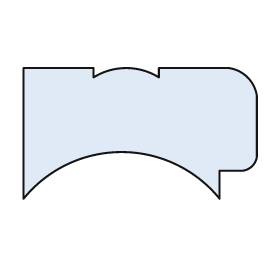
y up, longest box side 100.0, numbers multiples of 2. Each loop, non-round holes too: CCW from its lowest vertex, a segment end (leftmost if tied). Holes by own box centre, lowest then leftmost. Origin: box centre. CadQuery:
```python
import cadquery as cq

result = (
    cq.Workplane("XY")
    .moveTo(-50.0, -28.0)
    .threePointArc((-8.0, -8.0), (34.0, -28.0))
    .lineTo(34.0, -16.0)
    .lineTo(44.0, -16.0)
    .threePointArc((48.0, -14.0), (50.0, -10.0))
    .lineTo(50.0, 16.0)
    .threePointArc((46.0, 24.0), (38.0, 28.0))
    .lineTo(8.0, 28.0)
    .lineTo(8.0, 24.0)
    .threePointArc((-6.0, 28.0), (-20.0, 24.0))
    .lineTo(-20.0, 28.0)
    .lineTo(-50.0, 28.0)
    .close()
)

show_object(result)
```